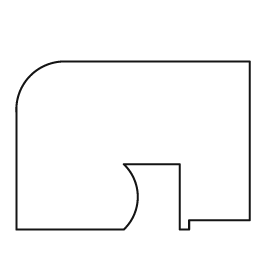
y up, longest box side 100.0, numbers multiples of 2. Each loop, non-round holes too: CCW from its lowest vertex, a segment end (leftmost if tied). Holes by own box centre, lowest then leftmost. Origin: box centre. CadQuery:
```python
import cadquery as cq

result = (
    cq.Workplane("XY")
    .moveTo(-50.0, -36.0)
    .lineTo(-4.0, -36.0)
    .threePointArc((2.0, -22.0), (-4.0, -8.0))
    .lineTo(20.0, -8.0)
    .lineTo(20.0, -36.0)
    .lineTo(24.0, -36.0)
    .lineTo(24.0, -32.0)
    .lineTo(50.0, -32.0)
    .lineTo(50.0, 36.0)
    .lineTo(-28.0, 36.0)
    .threePointArc((-44.0, 30.0), (-50.0, 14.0))
    .close()
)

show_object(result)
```